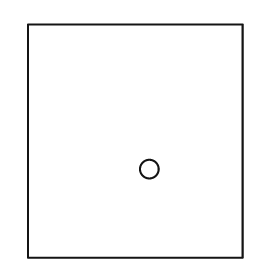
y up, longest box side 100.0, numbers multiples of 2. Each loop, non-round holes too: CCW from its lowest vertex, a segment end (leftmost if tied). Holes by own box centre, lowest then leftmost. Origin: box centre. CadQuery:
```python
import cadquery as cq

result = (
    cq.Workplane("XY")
    .moveTo(-46.0, -50.0)
    .lineTo(46.0, -50.0)
    .lineTo(46.0, 50.0)
    .lineTo(-46.0, 50.0)
    .close()
    .moveTo(6.0, -12.0)
    .circle(4.0)
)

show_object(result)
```